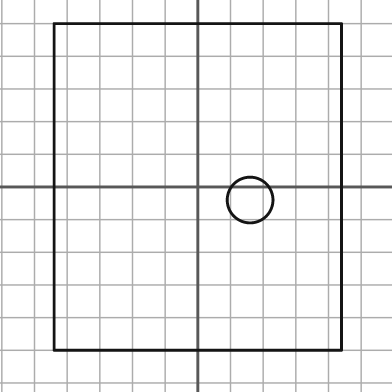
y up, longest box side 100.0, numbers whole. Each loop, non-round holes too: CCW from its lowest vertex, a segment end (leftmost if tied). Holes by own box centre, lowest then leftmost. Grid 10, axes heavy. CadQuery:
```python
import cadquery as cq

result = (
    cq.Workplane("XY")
    .moveTo(-44.0, -50.0)
    .lineTo(44.0, -50.0)
    .lineTo(44.0, 50.0)
    .lineTo(-44.0, 50.0)
    .close()
    .moveTo(16.0, -4.0)
    .circle(7.0)
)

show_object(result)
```